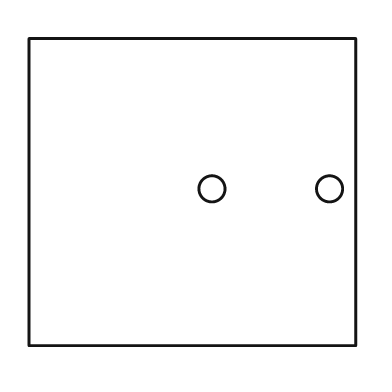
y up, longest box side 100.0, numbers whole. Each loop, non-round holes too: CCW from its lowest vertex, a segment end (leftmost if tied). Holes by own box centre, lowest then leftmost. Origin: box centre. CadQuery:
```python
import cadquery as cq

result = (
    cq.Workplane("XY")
    .moveTo(-50.0, -47.0)
    .lineTo(50.0, -47.0)
    .lineTo(50.0, 47.0)
    .lineTo(-50.0, 47.0)
    .close()
    .moveTo(6.0, 1.0)
    .circle(4.0)
    .moveTo(42.0, 1.0)
    .circle(4.0)
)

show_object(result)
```